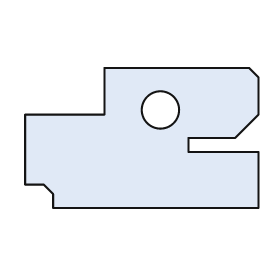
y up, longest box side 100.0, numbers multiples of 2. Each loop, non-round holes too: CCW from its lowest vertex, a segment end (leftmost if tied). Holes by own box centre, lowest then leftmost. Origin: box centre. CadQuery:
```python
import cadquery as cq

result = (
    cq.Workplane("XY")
    .moveTo(-38.0, -30.0)
    .lineTo(50.0, -30.0)
    .lineTo(50.0, -6.0)
    .lineTo(20.0, -6.0)
    .lineTo(20.0, 0.0)
    .lineTo(40.0, 0.0)
    .lineTo(50.0, 10.0)
    .lineTo(50.0, 26.0)
    .lineTo(46.0, 30.0)
    .lineTo(-16.0, 30.0)
    .lineTo(-16.0, 10.0)
    .lineTo(-50.0, 10.0)
    .lineTo(-50.0, -20.0)
    .lineTo(-42.0, -20.0)
    .lineTo(-38.0, -24.0)
    .close()
    .moveTo(8.0, 12.0)
    .circle(8.0)
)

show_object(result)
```